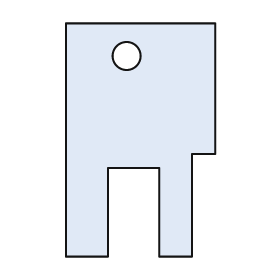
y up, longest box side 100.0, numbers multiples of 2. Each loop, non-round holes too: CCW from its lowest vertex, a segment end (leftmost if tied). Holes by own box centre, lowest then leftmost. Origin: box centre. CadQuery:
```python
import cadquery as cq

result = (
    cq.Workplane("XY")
    .moveTo(-32.0, -50.0)
    .lineTo(-14.0, -50.0)
    .lineTo(-14.0, -12.0)
    .lineTo(8.0, -12.0)
    .lineTo(8.0, -50.0)
    .lineTo(22.0, -50.0)
    .lineTo(22.0, -6.0)
    .lineTo(32.0, -6.0)
    .lineTo(32.0, 50.0)
    .lineTo(-32.0, 50.0)
    .close()
    .moveTo(-6.0, 36.0)
    .circle(6.0)
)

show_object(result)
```